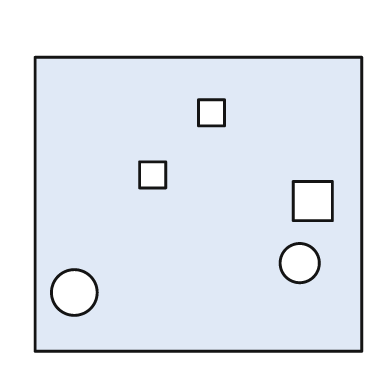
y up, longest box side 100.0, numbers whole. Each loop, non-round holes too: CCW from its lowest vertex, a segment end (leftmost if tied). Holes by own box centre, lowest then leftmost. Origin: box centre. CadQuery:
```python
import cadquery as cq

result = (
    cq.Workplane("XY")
    .moveTo(-50.0, -45.0)
    .lineTo(50.0, -45.0)
    .lineTo(50.0, 45.0)
    .lineTo(-50.0, 45.0)
    .close()
    .moveTo(-38.0, -27.0)
    .circle(7.0)
    .moveTo(31.0, -18.0)
    .circle(6.0)
    .moveTo(29.0, -5.0)
    .lineTo(41.0, -5.0)
    .lineTo(41.0, 7.0)
    .lineTo(29.0, 7.0)
    .close()
    .moveTo(-18.0, 5.0)
    .lineTo(-10.0, 5.0)
    .lineTo(-10.0, 13.0)
    .lineTo(-18.0, 13.0)
    .close()
    .moveTo(0.0, 24.0)
    .lineTo(8.0, 24.0)
    .lineTo(8.0, 32.0)
    .lineTo(0.0, 32.0)
    .close()
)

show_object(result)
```